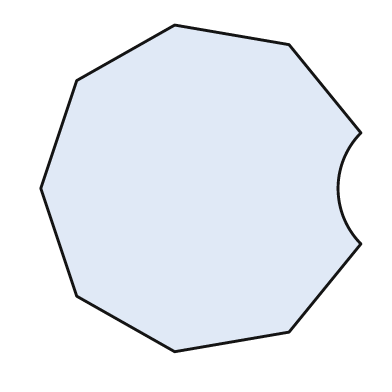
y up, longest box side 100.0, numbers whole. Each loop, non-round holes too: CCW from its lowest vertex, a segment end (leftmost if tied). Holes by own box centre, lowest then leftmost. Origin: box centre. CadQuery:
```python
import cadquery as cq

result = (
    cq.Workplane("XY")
    .moveTo(-8.0, -50.0)
    .lineTo(27.0, -44.0)
    .lineTo(49.0, -17.0)
    .threePointArc((42.0, 0.0), (49.0, 17.0))
    .lineTo(27.0, 44.0)
    .lineTo(-8.0, 50.0)
    .lineTo(-38.0, 33.0)
    .lineTo(-49.0, 0.0)
    .lineTo(-38.0, -33.0)
    .close()
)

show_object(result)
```